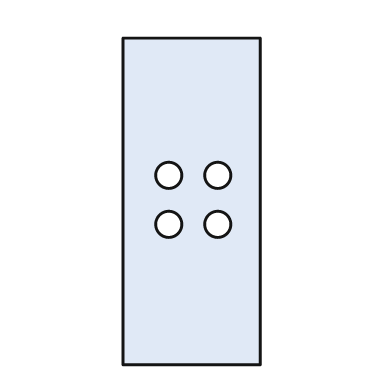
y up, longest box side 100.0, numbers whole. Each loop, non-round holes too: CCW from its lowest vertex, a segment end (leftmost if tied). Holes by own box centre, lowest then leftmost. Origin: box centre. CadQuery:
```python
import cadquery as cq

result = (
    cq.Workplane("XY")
    .moveTo(-21.0, -50.0)
    .lineTo(21.0, -50.0)
    .lineTo(21.0, 50.0)
    .lineTo(-21.0, 50.0)
    .close()
    .moveTo(-7.0, -7.0)
    .circle(4.0)
    .moveTo(8.0, -7.0)
    .circle(4.0)
    .moveTo(-7.0, 8.0)
    .circle(4.0)
    .moveTo(8.0, 8.0)
    .circle(4.0)
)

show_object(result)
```